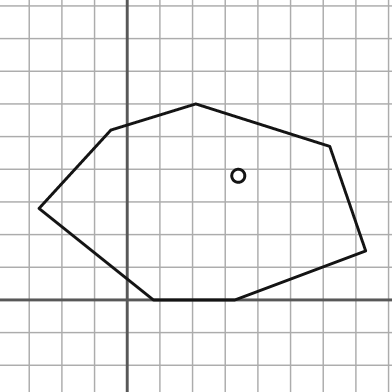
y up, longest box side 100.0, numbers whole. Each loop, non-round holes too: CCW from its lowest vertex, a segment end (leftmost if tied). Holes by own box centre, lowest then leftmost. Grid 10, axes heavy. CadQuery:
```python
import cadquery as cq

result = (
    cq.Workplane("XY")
    .moveTo(8.0, 0.0)
    .lineTo(33.0, 0.0)
    .lineTo(73.0, 15.0)
    .lineTo(62.0, 47.0)
    .lineTo(21.0, 60.0)
    .lineTo(-5.0, 52.0)
    .lineTo(-27.0, 28.0)
    .close()
    .moveTo(34.0, 38.0)
    .circle(2.0)
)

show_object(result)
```